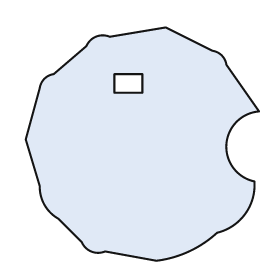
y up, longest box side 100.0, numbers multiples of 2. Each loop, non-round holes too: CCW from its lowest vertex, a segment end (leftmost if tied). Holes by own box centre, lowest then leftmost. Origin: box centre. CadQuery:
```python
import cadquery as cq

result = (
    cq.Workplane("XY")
    .moveTo(6.0, -50.0)
    .threePointArc((20.0, -46.0), (32.0, -38.0))
    .threePointArc((44.0, -30.0), (48.0, -16.0))
    .threePointArc((36.0, 0.0), (50.0, 14.0))
    .lineTo(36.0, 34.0)
    .threePointArc((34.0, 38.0), (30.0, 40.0))
    .lineTo(10.0, 50.0)
    .lineTo(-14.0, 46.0)
    .threePointArc((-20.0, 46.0), (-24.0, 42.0))
    .lineTo(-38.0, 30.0)
    .threePointArc((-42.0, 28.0), (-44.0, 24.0))
    .lineTo(-50.0, 2.0)
    .lineTo(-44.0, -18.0)
    .threePointArc((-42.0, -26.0), (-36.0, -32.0))
    .lineTo(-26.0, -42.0)
    .threePointArc((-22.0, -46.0), (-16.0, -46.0))
    .close()
    .moveTo(-12.0, 22.0)
    .lineTo(0.0, 22.0)
    .lineTo(0.0, 30.0)
    .lineTo(-12.0, 30.0)
    .close()
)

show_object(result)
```